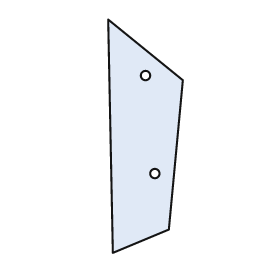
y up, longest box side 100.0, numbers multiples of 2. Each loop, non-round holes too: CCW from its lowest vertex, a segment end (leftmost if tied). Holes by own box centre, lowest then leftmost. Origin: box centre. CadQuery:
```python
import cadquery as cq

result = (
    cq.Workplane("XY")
    .moveTo(-14.0, -50.0)
    .lineTo(10.0, -40.0)
    .lineTo(16.0, 24.0)
    .lineTo(-16.0, 50.0)
    .close()
    .moveTo(4.0, -16.0)
    .circle(2.0)
    .moveTo(0.0, 26.0)
    .circle(2.0)
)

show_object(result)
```